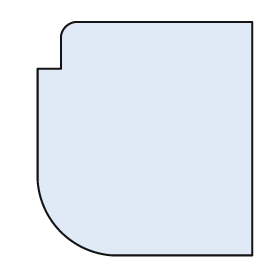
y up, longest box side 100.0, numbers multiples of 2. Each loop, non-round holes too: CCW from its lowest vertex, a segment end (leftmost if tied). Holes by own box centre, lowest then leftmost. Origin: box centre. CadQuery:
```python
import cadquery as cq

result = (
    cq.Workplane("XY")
    .moveTo(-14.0, -50.0)
    .lineTo(46.0, -50.0)
    .lineTo(46.0, 50.0)
    .lineTo(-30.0, 50.0)
    .threePointArc((-34.0, 48.0), (-36.0, 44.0))
    .lineTo(-36.0, 30.0)
    .lineTo(-46.0, 30.0)
    .lineTo(-46.0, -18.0)
    .threePointArc((-36.0, -40.0), (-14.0, -50.0))
    .close()
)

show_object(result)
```